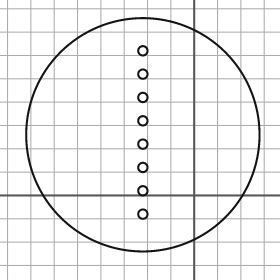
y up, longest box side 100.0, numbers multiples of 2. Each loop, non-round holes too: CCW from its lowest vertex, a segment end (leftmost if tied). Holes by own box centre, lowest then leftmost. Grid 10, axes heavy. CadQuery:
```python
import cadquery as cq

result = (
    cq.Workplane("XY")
    .moveTo(-22.0, 26.0)
    .circle(50.0)
    .moveTo(-22.0, -8.0)
    .circle(2.0)
    .moveTo(-22.0, 2.0)
    .circle(2.0)
    .moveTo(-22.0, 12.0)
    .circle(2.0)
    .moveTo(-22.0, 22.0)
    .circle(2.0)
    .moveTo(-22.0, 32.0)
    .circle(2.0)
    .moveTo(-22.0, 42.0)
    .circle(2.0)
    .moveTo(-22.0, 52.0)
    .circle(2.0)
    .moveTo(-22.0, 62.0)
    .circle(2.0)
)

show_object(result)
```